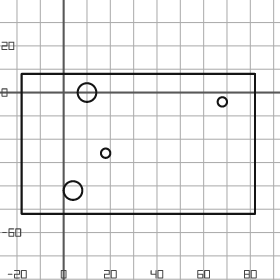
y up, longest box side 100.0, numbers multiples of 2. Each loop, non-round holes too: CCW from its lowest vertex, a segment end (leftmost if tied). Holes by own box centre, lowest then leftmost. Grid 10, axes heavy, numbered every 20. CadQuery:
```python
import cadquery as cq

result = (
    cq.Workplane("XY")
    .moveTo(-18.0, -52.0)
    .lineTo(82.0, -52.0)
    .lineTo(82.0, 8.0)
    .lineTo(-18.0, 8.0)
    .close()
    .moveTo(4.0, -42.0)
    .circle(4.0)
    .moveTo(18.0, -26.0)
    .circle(2.0)
    .moveTo(68.0, -4.0)
    .circle(2.0)
    .moveTo(10.0, 0.0)
    .circle(4.0)
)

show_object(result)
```